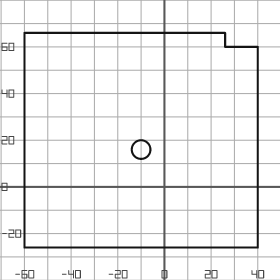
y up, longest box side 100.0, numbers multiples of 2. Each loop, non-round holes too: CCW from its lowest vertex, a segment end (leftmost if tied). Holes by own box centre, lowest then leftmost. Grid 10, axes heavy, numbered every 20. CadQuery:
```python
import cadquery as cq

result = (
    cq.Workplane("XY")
    .moveTo(-60.0, -26.0)
    .lineTo(40.0, -26.0)
    .lineTo(40.0, 60.0)
    .lineTo(26.0, 60.0)
    .lineTo(26.0, 66.0)
    .lineTo(-60.0, 66.0)
    .close()
    .moveTo(-10.0, 16.0)
    .circle(4.0)
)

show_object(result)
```